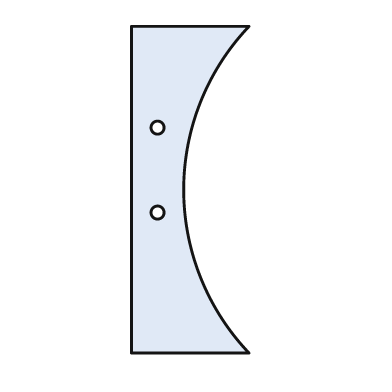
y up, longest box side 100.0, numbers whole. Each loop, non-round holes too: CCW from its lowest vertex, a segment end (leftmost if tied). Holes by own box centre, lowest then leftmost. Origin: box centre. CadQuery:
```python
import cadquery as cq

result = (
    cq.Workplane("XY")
    .moveTo(-18.0, -50.0)
    .lineTo(18.0, -50.0)
    .threePointArc((-2.0, 0.0), (18.0, 50.0))
    .lineTo(-18.0, 50.0)
    .close()
    .moveTo(-10.0, -7.0)
    .circle(2.0)
    .moveTo(-10.0, 19.0)
    .circle(2.0)
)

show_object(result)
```